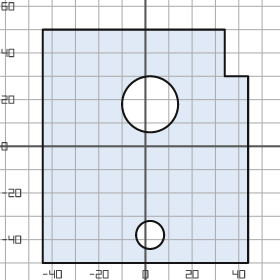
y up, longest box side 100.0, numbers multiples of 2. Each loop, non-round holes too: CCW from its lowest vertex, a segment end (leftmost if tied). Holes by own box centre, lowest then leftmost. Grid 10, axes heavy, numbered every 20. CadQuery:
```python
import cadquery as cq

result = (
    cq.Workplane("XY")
    .moveTo(-44.0, -50.0)
    .lineTo(44.0, -50.0)
    .lineTo(44.0, 30.0)
    .lineTo(34.0, 30.0)
    .lineTo(34.0, 50.0)
    .lineTo(-44.0, 50.0)
    .close()
    .moveTo(2.0, -38.0)
    .circle(6.0)
    .moveTo(2.0, 18.0)
    .circle(12.0)
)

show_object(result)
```